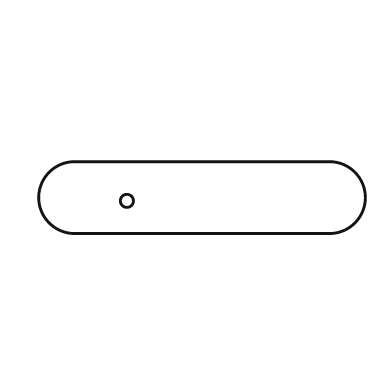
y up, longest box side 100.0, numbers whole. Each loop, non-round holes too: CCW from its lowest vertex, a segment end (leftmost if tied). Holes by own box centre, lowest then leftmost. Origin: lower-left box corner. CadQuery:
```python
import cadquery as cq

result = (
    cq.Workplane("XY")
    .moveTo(11.0, 0.0)
    .lineTo(89.0, 0.0)
    .threePointArc((100.0, 11.0), (89.0, 22.0))
    .lineTo(11.0, 22.0)
    .threePointArc((0.0, 11.0), (11.0, 0.0))
    .close()
    .moveTo(27.0, 10.0)
    .circle(2.0)
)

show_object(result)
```